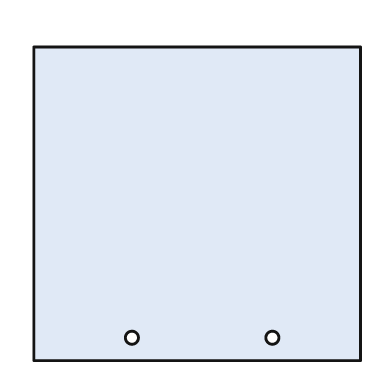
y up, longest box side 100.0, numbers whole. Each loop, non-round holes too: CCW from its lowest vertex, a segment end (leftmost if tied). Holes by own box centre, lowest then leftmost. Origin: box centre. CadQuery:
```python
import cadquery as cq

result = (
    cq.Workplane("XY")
    .moveTo(-50.0, -48.0)
    .lineTo(50.0, -48.0)
    .lineTo(50.0, 48.0)
    .lineTo(-50.0, 48.0)
    .close()
    .moveTo(-20.0, -41.0)
    .circle(2.0)
    .moveTo(23.0, -41.0)
    .circle(2.0)
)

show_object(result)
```